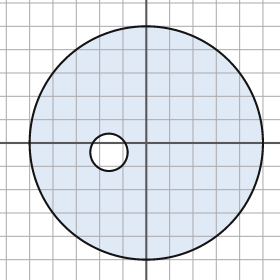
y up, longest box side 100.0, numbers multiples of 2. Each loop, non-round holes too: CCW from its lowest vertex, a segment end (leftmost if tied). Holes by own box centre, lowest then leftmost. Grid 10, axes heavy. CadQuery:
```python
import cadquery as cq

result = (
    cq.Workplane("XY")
    .moveTo(0.0, 0.0)
    .circle(50.0)
    .moveTo(-16.0, -4.0)
    .circle(8.0)
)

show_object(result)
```